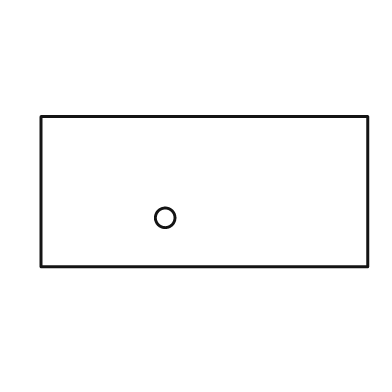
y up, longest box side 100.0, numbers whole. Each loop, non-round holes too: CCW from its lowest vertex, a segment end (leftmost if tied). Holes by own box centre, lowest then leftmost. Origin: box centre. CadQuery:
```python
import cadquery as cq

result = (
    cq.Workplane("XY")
    .moveTo(-50.0, -23.0)
    .lineTo(50.0, -23.0)
    .lineTo(50.0, 23.0)
    .lineTo(-50.0, 23.0)
    .close()
    .moveTo(-12.0, -8.0)
    .circle(3.0)
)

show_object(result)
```